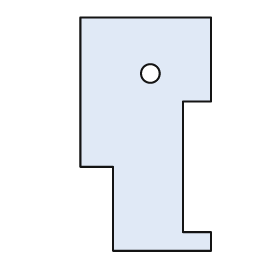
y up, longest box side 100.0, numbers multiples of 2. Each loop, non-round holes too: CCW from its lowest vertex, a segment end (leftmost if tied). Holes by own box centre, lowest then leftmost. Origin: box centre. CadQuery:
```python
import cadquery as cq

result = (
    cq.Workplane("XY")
    .moveTo(-14.0, -50.0)
    .lineTo(28.0, -50.0)
    .lineTo(28.0, -42.0)
    .lineTo(16.0, -42.0)
    .lineTo(16.0, 14.0)
    .lineTo(28.0, 14.0)
    .lineTo(28.0, 50.0)
    .lineTo(-28.0, 50.0)
    .lineTo(-28.0, -14.0)
    .lineTo(-14.0, -14.0)
    .close()
    .moveTo(2.0, 26.0)
    .circle(4.0)
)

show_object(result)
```